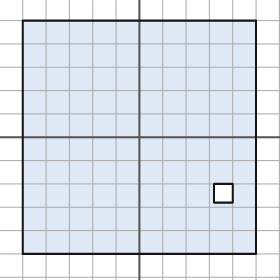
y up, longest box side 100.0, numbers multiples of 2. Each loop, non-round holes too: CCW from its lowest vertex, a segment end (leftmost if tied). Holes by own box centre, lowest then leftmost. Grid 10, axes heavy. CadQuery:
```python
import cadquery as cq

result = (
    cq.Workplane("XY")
    .moveTo(-50.0, -50.0)
    .lineTo(50.0, -50.0)
    .lineTo(50.0, 50.0)
    .lineTo(-50.0, 50.0)
    .close()
    .moveTo(32.0, -28.0)
    .lineTo(40.0, -28.0)
    .lineTo(40.0, -20.0)
    .lineTo(32.0, -20.0)
    .close()
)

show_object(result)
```